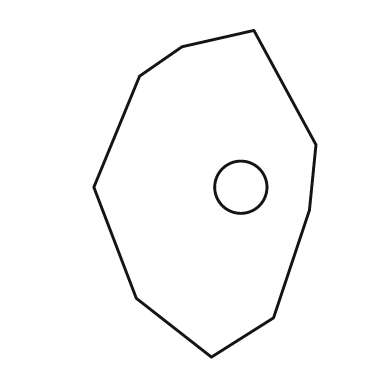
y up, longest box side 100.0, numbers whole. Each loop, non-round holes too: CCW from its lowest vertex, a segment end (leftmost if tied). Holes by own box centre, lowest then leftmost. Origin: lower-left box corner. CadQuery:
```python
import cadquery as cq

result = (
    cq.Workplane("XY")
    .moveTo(36.0, 0.0)
    .lineTo(55.0, 12.0)
    .lineTo(66.0, 45.0)
    .lineTo(68.0, 65.0)
    .lineTo(49.0, 100.0)
    .lineTo(27.0, 95.0)
    .lineTo(14.0, 86.0)
    .lineTo(0.0, 52.0)
    .lineTo(13.0, 18.0)
    .close()
    .moveTo(45.0, 52.0)
    .circle(8.0)
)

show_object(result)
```